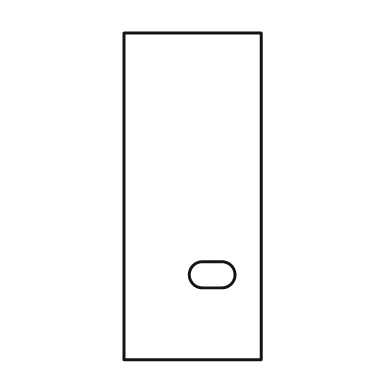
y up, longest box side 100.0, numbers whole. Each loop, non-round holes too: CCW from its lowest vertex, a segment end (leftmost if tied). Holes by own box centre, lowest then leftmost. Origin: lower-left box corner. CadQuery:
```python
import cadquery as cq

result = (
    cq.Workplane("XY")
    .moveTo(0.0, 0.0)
    .lineTo(42.0, 0.0)
    .lineTo(42.0, 100.0)
    .lineTo(0.0, 100.0)
    .close()
    .moveTo(24.0, 22.0)
    .lineTo(30.0, 22.0)
    .threePointArc((34.0, 26.0), (30.0, 30.0))
    .lineTo(24.0, 30.0)
    .threePointArc((20.0, 26.0), (24.0, 22.0))
    .close()
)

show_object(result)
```